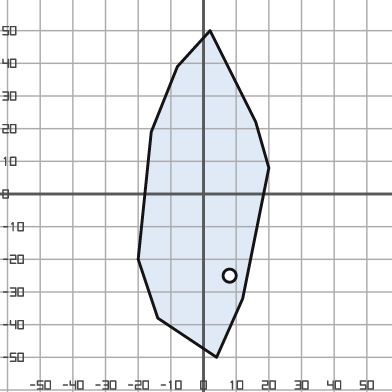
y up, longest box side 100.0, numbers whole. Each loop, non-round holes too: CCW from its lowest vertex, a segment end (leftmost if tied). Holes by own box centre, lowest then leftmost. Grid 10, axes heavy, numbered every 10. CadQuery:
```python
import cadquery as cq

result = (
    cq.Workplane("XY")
    .moveTo(4.0, -50.0)
    .lineTo(12.0, -32.0)
    .lineTo(20.0, 8.0)
    .lineTo(16.0, 22.0)
    .lineTo(2.0, 50.0)
    .lineTo(-8.0, 39.0)
    .lineTo(-16.0, 19.0)
    .lineTo(-20.0, -20.0)
    .lineTo(-14.0, -38.0)
    .close()
    .moveTo(8.0, -25.0)
    .circle(2.0)
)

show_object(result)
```